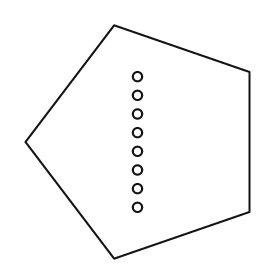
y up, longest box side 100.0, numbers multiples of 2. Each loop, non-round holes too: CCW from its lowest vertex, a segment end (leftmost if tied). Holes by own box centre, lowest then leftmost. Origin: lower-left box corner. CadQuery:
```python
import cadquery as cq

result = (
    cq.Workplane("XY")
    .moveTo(38.0, 0.0)
    .lineTo(96.0, 20.0)
    .lineTo(96.0, 80.0)
    .lineTo(38.0, 100.0)
    .lineTo(0.0, 50.0)
    .close()
    .moveTo(48.0, 22.0)
    .circle(2.0)
    .moveTo(48.0, 30.0)
    .circle(2.0)
    .moveTo(48.0, 38.0)
    .circle(2.0)
    .moveTo(48.0, 46.0)
    .circle(2.0)
    .moveTo(48.0, 54.0)
    .circle(2.0)
    .moveTo(48.0, 62.0)
    .circle(2.0)
    .moveTo(48.0, 70.0)
    .circle(2.0)
    .moveTo(48.0, 78.0)
    .circle(2.0)
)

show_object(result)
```